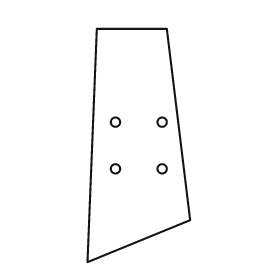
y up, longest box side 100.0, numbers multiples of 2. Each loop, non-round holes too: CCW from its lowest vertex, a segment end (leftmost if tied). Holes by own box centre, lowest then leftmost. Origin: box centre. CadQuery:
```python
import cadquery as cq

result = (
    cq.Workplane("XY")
    .moveTo(-22.0, -50.0)
    .lineTo(22.0, -32.0)
    .lineTo(12.0, 50.0)
    .lineTo(-18.0, 50.0)
    .close()
    .moveTo(-10.0, -10.0)
    .circle(2.0)
    .moveTo(10.0, -10.0)
    .circle(2.0)
    .moveTo(-10.0, 10.0)
    .circle(2.0)
    .moveTo(10.0, 10.0)
    .circle(2.0)
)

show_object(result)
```